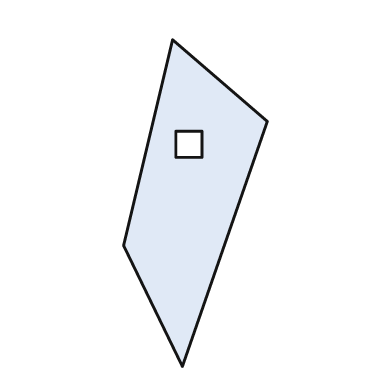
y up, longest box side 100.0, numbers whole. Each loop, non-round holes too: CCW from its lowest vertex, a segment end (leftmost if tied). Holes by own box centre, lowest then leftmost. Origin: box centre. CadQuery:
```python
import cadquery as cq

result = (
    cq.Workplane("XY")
    .moveTo(-4.0, -50.0)
    .lineTo(22.0, 25.0)
    .lineTo(-7.0, 50.0)
    .lineTo(-22.0, -13.0)
    .close()
    .moveTo(-6.0, 14.0)
    .lineTo(2.0, 14.0)
    .lineTo(2.0, 22.0)
    .lineTo(-6.0, 22.0)
    .close()
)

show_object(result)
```